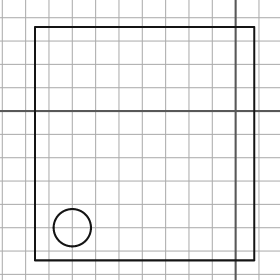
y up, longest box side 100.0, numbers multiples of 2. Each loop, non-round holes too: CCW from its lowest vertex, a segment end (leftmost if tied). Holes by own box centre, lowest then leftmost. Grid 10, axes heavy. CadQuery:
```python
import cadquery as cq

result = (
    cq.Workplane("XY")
    .moveTo(-86.0, -64.0)
    .lineTo(8.0, -64.0)
    .lineTo(8.0, 36.0)
    .lineTo(-86.0, 36.0)
    .close()
    .moveTo(-70.0, -50.0)
    .circle(8.0)
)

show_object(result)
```